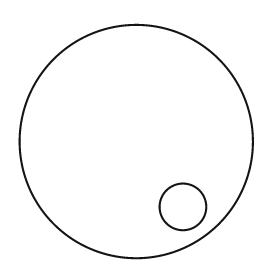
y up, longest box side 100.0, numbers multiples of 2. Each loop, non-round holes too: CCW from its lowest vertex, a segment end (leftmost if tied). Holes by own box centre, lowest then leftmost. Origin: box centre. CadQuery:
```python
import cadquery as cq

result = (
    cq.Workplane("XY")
    .moveTo(0.0, 0.0)
    .circle(50.0)
    .moveTo(20.0, -28.0)
    .circle(10.0)
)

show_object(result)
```